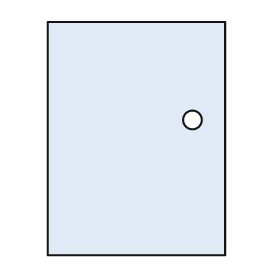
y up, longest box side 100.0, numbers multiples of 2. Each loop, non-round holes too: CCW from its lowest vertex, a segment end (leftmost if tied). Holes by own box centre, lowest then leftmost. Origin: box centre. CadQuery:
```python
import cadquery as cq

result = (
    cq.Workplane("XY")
    .moveTo(-38.0, -50.0)
    .lineTo(38.0, -50.0)
    .lineTo(38.0, 50.0)
    .lineTo(-38.0, 50.0)
    .close()
    .moveTo(24.0, 8.0)
    .circle(4.0)
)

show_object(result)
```